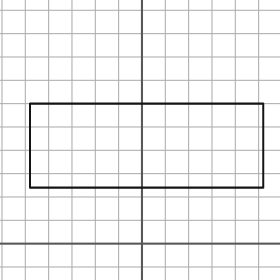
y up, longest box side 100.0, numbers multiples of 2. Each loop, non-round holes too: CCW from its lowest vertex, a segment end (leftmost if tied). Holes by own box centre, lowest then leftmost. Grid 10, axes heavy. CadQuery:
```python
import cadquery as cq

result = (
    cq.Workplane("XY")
    .moveTo(-48.0, 24.0)
    .lineTo(52.0, 24.0)
    .lineTo(52.0, 60.0)
    .lineTo(-48.0, 60.0)
    .close()
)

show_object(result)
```